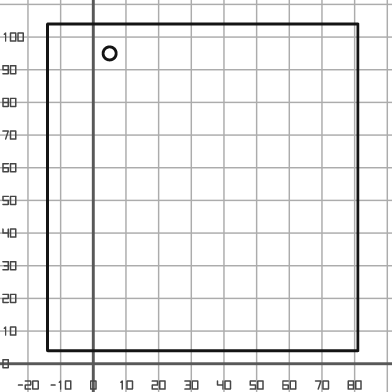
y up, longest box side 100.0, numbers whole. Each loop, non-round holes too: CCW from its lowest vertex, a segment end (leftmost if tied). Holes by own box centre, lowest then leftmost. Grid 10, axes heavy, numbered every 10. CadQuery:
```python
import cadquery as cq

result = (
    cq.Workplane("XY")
    .moveTo(-14.0, 4.0)
    .lineTo(81.0, 4.0)
    .lineTo(81.0, 104.0)
    .lineTo(-14.0, 104.0)
    .close()
    .moveTo(5.0, 95.0)
    .circle(2.0)
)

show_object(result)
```